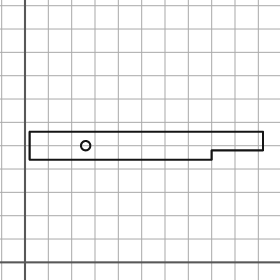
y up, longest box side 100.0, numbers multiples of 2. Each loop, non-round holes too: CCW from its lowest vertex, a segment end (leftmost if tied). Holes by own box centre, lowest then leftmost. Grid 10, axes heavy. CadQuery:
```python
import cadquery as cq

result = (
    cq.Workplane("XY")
    .moveTo(2.0, 44.0)
    .lineTo(80.0, 44.0)
    .lineTo(80.0, 48.0)
    .lineTo(102.0, 48.0)
    .lineTo(102.0, 56.0)
    .lineTo(2.0, 56.0)
    .close()
    .moveTo(26.0, 50.0)
    .circle(2.0)
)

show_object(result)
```